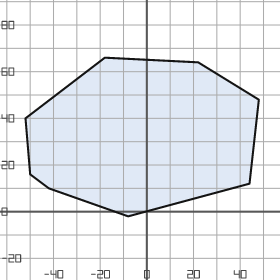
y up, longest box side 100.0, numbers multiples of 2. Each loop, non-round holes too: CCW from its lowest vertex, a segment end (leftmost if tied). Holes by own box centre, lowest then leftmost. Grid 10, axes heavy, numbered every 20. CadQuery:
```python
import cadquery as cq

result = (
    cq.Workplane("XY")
    .moveTo(-8.0, -2.0)
    .lineTo(44.0, 12.0)
    .lineTo(48.0, 48.0)
    .lineTo(22.0, 64.0)
    .lineTo(-18.0, 66.0)
    .lineTo(-52.0, 40.0)
    .lineTo(-50.0, 16.0)
    .lineTo(-42.0, 10.0)
    .close()
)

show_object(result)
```